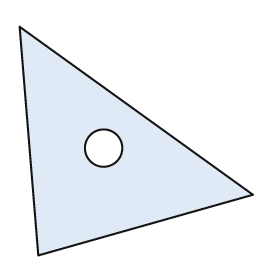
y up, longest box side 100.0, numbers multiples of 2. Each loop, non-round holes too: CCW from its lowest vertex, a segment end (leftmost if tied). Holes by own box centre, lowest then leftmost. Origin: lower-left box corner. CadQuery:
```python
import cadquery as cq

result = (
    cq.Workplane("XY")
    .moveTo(8.0, 0.0)
    .lineTo(100.0, 26.0)
    .lineTo(0.0, 98.0)
    .close()
    .moveTo(36.0, 46.0)
    .circle(8.0)
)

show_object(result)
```